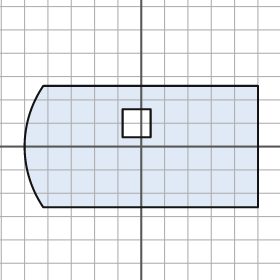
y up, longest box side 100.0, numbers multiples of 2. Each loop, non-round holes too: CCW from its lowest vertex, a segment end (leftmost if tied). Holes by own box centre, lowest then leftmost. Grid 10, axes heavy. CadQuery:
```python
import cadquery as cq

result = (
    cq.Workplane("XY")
    .moveTo(-42.0, -26.0)
    .lineTo(50.0, -26.0)
    .lineTo(50.0, 26.0)
    .lineTo(-42.0, 26.0)
    .threePointArc((-50.0, 0.0), (-42.0, -26.0))
    .close()
    .moveTo(-8.0, 4.0)
    .lineTo(4.0, 4.0)
    .lineTo(4.0, 16.0)
    .lineTo(-8.0, 16.0)
    .close()
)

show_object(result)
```